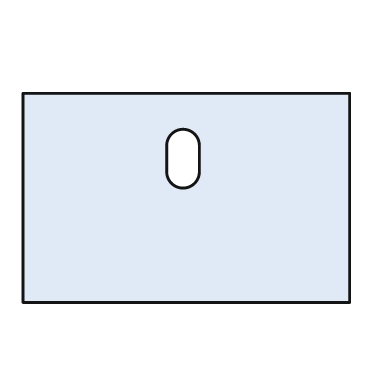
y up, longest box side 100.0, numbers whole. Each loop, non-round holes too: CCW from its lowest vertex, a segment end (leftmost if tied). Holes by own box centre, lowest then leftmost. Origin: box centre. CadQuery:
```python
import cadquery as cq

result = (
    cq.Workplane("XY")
    .moveTo(-50.0, -32.0)
    .lineTo(50.0, -32.0)
    .lineTo(50.0, 32.0)
    .lineTo(-50.0, 32.0)
    .close()
    .moveTo(-6.0, 8.0)
    .threePointArc((-1.0, 3.0), (4.0, 8.0))
    .lineTo(4.0, 16.0)
    .threePointArc((-1.0, 21.0), (-6.0, 16.0))
    .close()
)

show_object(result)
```